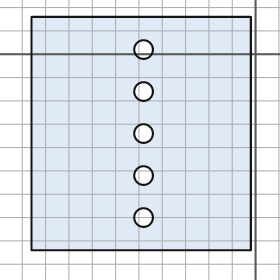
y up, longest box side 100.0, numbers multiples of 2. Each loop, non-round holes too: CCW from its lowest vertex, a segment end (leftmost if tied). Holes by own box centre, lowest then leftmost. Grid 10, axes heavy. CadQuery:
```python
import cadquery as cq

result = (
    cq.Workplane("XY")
    .moveTo(-96.0, -84.0)
    .lineTo(-2.0, -84.0)
    .lineTo(-2.0, 16.0)
    .lineTo(-96.0, 16.0)
    .close()
    .moveTo(-48.0, -70.0)
    .circle(4.0)
    .moveTo(-48.0, -52.0)
    .circle(4.0)
    .moveTo(-48.0, -34.0)
    .circle(4.0)
    .moveTo(-48.0, -16.0)
    .circle(4.0)
    .moveTo(-48.0, 2.0)
    .circle(4.0)
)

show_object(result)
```